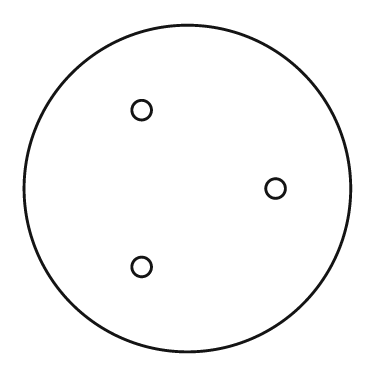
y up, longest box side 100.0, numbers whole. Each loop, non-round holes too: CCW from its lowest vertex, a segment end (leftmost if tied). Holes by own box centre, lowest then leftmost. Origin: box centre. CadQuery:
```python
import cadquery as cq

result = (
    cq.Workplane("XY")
    .moveTo(0.0, 0.0)
    .circle(50.0)
    .moveTo(-14.0, -24.0)
    .circle(3.0)
    .moveTo(27.0, 0.0)
    .circle(3.0)
    .moveTo(-14.0, 24.0)
    .circle(3.0)
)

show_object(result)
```